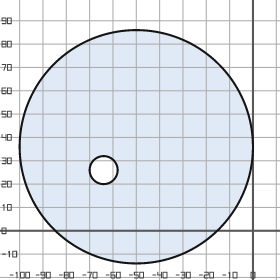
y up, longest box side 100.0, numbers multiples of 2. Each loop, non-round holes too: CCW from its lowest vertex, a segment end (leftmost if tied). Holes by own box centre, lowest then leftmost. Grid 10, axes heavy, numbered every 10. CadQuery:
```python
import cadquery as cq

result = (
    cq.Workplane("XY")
    .moveTo(-50.0, 36.0)
    .circle(50.0)
    .moveTo(-64.0, 26.0)
    .circle(6.0)
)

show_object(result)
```